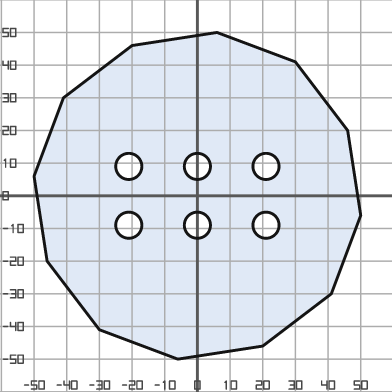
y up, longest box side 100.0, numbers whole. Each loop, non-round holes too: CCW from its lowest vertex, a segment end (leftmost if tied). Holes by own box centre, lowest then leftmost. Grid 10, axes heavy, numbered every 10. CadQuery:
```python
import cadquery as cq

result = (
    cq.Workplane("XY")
    .moveTo(-6.0, -50.0)
    .lineTo(20.0, -46.0)
    .lineTo(41.0, -30.0)
    .lineTo(50.0, -6.0)
    .lineTo(46.0, 20.0)
    .lineTo(30.0, 41.0)
    .lineTo(6.0, 50.0)
    .lineTo(-20.0, 46.0)
    .lineTo(-41.0, 30.0)
    .lineTo(-50.0, 6.0)
    .lineTo(-46.0, -20.0)
    .lineTo(-30.0, -41.0)
    .close()
    .moveTo(-21.0, -9.0)
    .circle(4.0)
    .moveTo(0.0, -9.0)
    .circle(4.0)
    .moveTo(21.0, -9.0)
    .circle(4.0)
    .moveTo(-21.0, 9.0)
    .circle(4.0)
    .moveTo(0.0, 9.0)
    .circle(4.0)
    .moveTo(21.0, 9.0)
    .circle(4.0)
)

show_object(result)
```